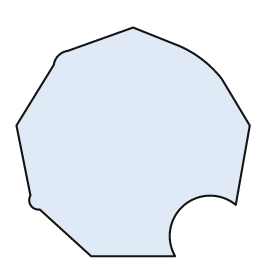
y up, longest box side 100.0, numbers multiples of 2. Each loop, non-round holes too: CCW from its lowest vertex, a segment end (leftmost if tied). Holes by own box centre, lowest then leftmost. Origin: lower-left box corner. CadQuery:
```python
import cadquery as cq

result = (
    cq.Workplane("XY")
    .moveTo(32.0, 0.0)
    .lineTo(68.0, 0.0)
    .threePointArc((72.0, 22.0), (94.0, 22.0))
    .lineTo(100.0, 56.0)
    .lineTo(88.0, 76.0)
    .threePointArc((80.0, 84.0), (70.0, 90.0))
    .lineTo(50.0, 98.0)
    .lineTo(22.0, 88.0)
    .threePointArc((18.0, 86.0), (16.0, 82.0))
    .lineTo(0.0, 56.0)
    .lineTo(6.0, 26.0)
    .threePointArc((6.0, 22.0), (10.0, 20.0))
    .close()
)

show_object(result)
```